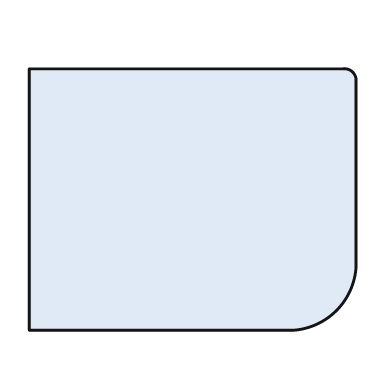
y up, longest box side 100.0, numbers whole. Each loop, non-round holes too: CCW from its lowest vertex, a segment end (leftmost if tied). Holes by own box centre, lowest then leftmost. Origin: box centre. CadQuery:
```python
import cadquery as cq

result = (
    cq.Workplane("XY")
    .moveTo(-50.0, -40.0)
    .lineTo(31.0, -40.0)
    .threePointArc((44.0, -34.0), (50.0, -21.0))
    .lineTo(50.0, 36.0)
    .threePointArc((49.0, 39.0), (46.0, 40.0))
    .lineTo(-50.0, 40.0)
    .close()
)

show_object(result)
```